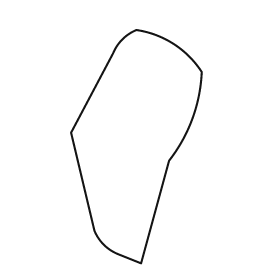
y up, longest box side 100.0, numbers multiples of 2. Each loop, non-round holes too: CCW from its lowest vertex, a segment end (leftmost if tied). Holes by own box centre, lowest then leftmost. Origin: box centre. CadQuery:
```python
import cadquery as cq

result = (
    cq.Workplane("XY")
    .moveTo(2.0, -50.0)
    .lineTo(14.0, -6.0)
    .threePointArc((24.0, 12.0), (28.0, 32.0))
    .threePointArc((16.0, 44.0), (0.0, 50.0))
    .threePointArc((-6.0, 46.0), (-10.0, 40.0))
    .lineTo(-28.0, 6.0)
    .lineTo(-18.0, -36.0)
    .threePointArc((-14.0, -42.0), (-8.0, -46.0))
    .close()
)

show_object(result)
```